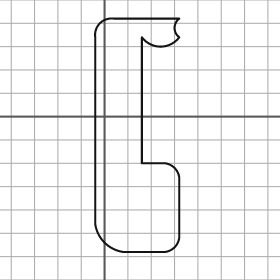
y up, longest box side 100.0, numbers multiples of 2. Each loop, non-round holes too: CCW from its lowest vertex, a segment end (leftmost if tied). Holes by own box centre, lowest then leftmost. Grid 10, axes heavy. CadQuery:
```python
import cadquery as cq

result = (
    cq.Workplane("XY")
    .moveTo(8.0, -58.0)
    .lineTo(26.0, -58.0)
    .threePointArc((30.0, -56.0), (32.0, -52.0))
    .lineTo(32.0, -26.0)
    .threePointArc((30.0, -22.0), (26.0, -20.0))
    .lineTo(16.0, -20.0)
    .lineTo(16.0, 34.0)
    .threePointArc((24.0, 30.0), (32.0, 34.0))
    .threePointArc((30.0, 38.0), (32.0, 42.0))
    .lineTo(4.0, 42.0)
    .threePointArc((-2.0, 40.0), (-4.0, 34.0))
    .lineTo(-4.0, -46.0)
    .threePointArc((0.0, -54.0), (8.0, -58.0))
    .close()
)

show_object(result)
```